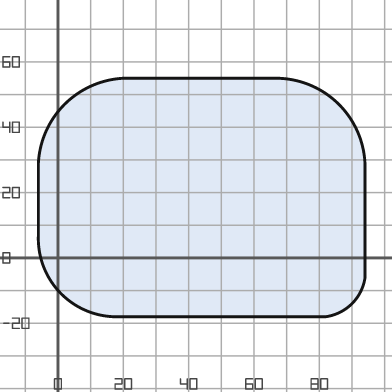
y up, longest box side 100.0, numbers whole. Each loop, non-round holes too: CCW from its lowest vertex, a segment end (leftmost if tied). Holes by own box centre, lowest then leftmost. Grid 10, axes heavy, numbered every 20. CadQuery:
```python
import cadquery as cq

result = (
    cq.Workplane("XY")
    .moveTo(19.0, -18.0)
    .lineTo(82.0, -18.0)
    .threePointArc((90.0, -14.0), (94.0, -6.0))
    .lineTo(94.0, 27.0)
    .threePointArc((86.0, 47.0), (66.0, 55.0))
    .lineTo(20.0, 55.0)
    .threePointArc((2.0, 47.0), (-6.0, 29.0))
    .lineTo(-6.0, 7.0)
    .threePointArc((1.0, -11.0), (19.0, -18.0))
    .close()
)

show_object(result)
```